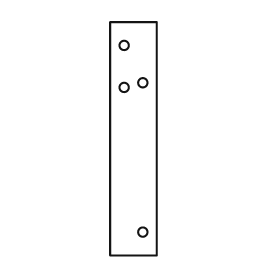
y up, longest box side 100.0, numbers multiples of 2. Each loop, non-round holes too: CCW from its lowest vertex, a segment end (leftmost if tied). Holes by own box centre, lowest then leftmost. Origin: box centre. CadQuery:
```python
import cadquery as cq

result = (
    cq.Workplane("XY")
    .moveTo(-10.0, -50.0)
    .lineTo(10.0, -50.0)
    .lineTo(10.0, 50.0)
    .lineTo(-10.0, 50.0)
    .close()
    .moveTo(4.0, -40.0)
    .circle(2.0)
    .moveTo(-4.0, 22.0)
    .circle(2.0)
    .moveTo(4.0, 24.0)
    .circle(2.0)
    .moveTo(-4.0, 40.0)
    .circle(2.0)
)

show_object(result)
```